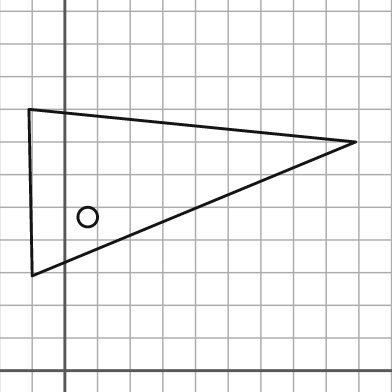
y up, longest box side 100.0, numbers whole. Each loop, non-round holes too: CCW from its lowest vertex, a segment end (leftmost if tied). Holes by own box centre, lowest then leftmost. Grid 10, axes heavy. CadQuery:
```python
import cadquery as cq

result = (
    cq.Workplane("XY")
    .moveTo(-10.0, 29.0)
    .lineTo(89.0, 70.0)
    .lineTo(-11.0, 80.0)
    .close()
    .moveTo(7.0, 47.0)
    .circle(3.0)
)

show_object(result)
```